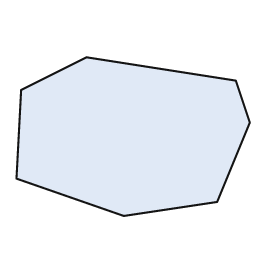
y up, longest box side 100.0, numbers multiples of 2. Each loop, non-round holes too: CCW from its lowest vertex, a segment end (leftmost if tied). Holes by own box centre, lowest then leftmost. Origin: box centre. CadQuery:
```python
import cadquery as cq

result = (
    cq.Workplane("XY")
    .moveTo(-4.0, -34.0)
    .lineTo(36.0, -28.0)
    .lineTo(50.0, 6.0)
    .lineTo(44.0, 24.0)
    .lineTo(-20.0, 34.0)
    .lineTo(-48.0, 20.0)
    .lineTo(-50.0, -18.0)
    .close()
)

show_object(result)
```